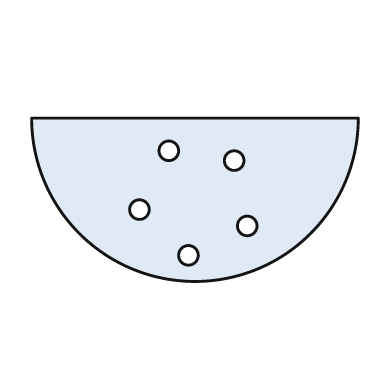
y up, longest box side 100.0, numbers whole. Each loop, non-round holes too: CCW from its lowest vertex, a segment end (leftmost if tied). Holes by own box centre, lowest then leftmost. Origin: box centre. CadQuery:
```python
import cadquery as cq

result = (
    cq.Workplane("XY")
    .moveTo(-50.0, 25.0)
    .threePointArc((0.0, -25.0), (50.0, 25.0))
    .close()
    .moveTo(-2.0, -17.0)
    .circle(3.0)
    .moveTo(16.0, -8.0)
    .circle(3.0)
    .moveTo(-17.0, -3.0)
    .circle(3.0)
    .moveTo(12.0, 12.0)
    .circle(3.0)
    .moveTo(-8.0, 15.0)
    .circle(3.0)
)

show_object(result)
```